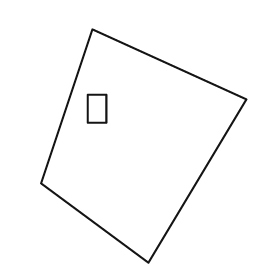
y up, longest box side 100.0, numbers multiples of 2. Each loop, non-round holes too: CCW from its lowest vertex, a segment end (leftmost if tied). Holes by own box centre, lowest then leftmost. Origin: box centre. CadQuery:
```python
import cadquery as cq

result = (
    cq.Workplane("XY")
    .moveTo(2.0, -50.0)
    .lineTo(44.0, 20.0)
    .lineTo(-22.0, 50.0)
    .lineTo(-44.0, -16.0)
    .close()
    .moveTo(-24.0, 10.0)
    .lineTo(-16.0, 10.0)
    .lineTo(-16.0, 22.0)
    .lineTo(-24.0, 22.0)
    .close()
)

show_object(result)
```